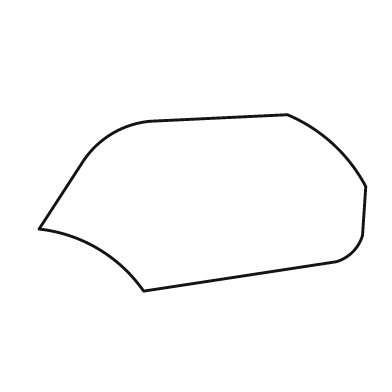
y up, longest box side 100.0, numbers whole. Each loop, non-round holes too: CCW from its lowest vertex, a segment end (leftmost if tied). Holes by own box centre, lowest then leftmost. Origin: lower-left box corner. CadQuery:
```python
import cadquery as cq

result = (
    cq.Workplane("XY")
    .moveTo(32.0, 0.0)
    .lineTo(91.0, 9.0)
    .threePointArc((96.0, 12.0), (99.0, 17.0))
    .lineTo(100.0, 32.0)
    .threePointArc((90.0, 45.0), (76.0, 54.0))
    .lineTo(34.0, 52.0)
    .threePointArc((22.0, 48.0), (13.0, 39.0))
    .lineTo(0.0, 19.0)
    .threePointArc((18.0, 13.0), (32.0, 0.0))
    .close()
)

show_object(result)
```